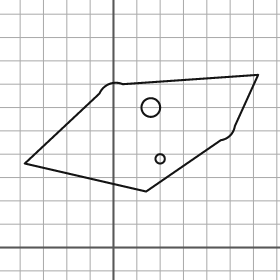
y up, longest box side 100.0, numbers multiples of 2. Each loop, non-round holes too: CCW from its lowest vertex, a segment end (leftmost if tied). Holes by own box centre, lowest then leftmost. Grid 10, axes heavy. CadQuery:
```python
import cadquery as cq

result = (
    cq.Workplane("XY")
    .moveTo(14.0, 24.0)
    .lineTo(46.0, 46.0)
    .threePointArc((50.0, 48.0), (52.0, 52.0))
    .lineTo(62.0, 74.0)
    .lineTo(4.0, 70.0)
    .threePointArc((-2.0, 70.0), (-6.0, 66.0))
    .lineTo(-38.0, 36.0)
    .close()
    .moveTo(20.0, 38.0)
    .circle(2.0)
    .moveTo(16.0, 60.0)
    .circle(4.0)
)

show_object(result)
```